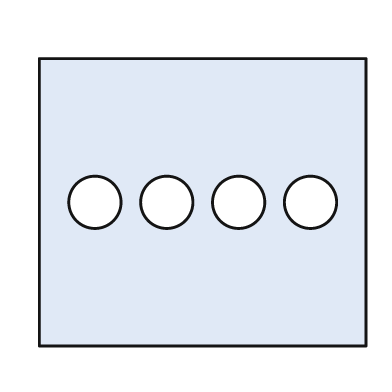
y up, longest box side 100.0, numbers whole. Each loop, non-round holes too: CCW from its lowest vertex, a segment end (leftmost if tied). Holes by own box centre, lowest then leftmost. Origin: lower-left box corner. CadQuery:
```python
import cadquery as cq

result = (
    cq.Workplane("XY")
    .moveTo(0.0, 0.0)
    .lineTo(100.0, 0.0)
    .lineTo(100.0, 88.0)
    .lineTo(0.0, 88.0)
    .close()
    .moveTo(17.0, 44.0)
    .circle(8.0)
    .moveTo(39.0, 44.0)
    .circle(8.0)
    .moveTo(61.0, 44.0)
    .circle(8.0)
    .moveTo(83.0, 44.0)
    .circle(8.0)
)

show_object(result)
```